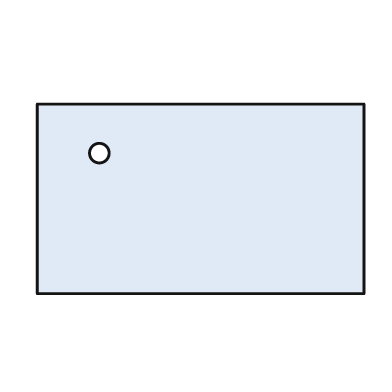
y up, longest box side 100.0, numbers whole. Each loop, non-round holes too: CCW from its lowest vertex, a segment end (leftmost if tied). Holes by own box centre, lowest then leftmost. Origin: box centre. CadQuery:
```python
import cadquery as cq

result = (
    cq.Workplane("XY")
    .moveTo(-50.0, -29.0)
    .lineTo(50.0, -29.0)
    .lineTo(50.0, 29.0)
    .lineTo(-50.0, 29.0)
    .close()
    .moveTo(-31.0, 14.0)
    .circle(3.0)
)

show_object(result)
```